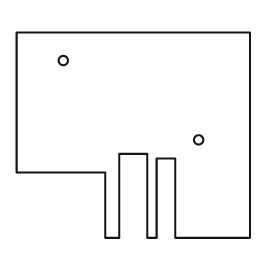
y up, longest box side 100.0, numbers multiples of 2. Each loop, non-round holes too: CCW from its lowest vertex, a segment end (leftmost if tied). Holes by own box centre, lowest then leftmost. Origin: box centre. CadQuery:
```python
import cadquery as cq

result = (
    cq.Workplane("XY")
    .moveTo(-12.0, -44.0)
    .lineTo(-6.0, -44.0)
    .lineTo(-6.0, -8.0)
    .lineTo(6.0, -8.0)
    .lineTo(6.0, -44.0)
    .lineTo(10.0, -44.0)
    .lineTo(10.0, -10.0)
    .lineTo(18.0, -10.0)
    .lineTo(18.0, -44.0)
    .lineTo(50.0, -44.0)
    .lineTo(50.0, 44.0)
    .lineTo(-50.0, 44.0)
    .lineTo(-50.0, -16.0)
    .lineTo(-12.0, -16.0)
    .close()
    .moveTo(28.0, -2.0)
    .circle(2.0)
    .moveTo(-30.0, 32.0)
    .circle(2.0)
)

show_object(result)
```